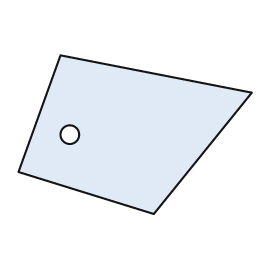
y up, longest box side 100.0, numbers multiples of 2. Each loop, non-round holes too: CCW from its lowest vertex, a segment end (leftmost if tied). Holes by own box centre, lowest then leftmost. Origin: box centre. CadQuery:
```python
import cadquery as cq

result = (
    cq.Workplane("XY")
    .moveTo(8.0, -34.0)
    .lineTo(50.0, 18.0)
    .lineTo(-32.0, 34.0)
    .lineTo(-50.0, -16.0)
    .close()
    .moveTo(-28.0, 0.0)
    .circle(4.0)
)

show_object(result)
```